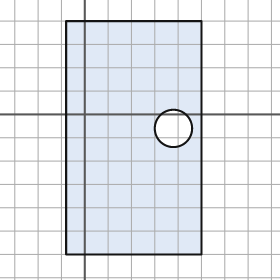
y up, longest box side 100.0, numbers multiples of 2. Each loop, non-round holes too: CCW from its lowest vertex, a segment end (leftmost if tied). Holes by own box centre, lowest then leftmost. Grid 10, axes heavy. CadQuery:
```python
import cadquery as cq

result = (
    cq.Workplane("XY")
    .moveTo(-8.0, -60.0)
    .lineTo(50.0, -60.0)
    .lineTo(50.0, 40.0)
    .lineTo(-8.0, 40.0)
    .close()
    .moveTo(38.0, -6.0)
    .circle(8.0)
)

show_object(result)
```